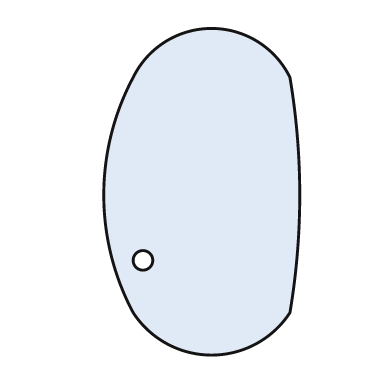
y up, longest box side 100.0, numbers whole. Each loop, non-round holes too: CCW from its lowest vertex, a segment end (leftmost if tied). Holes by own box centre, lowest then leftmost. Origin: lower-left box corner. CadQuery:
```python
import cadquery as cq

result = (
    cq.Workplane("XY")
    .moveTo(9.0, 13.0)
    .threePointArc((33.0, 0.0), (57.0, 13.0))
    .threePointArc((60.0, 49.0), (57.0, 85.0))
    .threePointArc((33.0, 100.0), (9.0, 85.0))
    .threePointArc((0.0, 49.0), (9.0, 13.0))
    .close()
    .moveTo(12.0, 29.0)
    .circle(3.0)
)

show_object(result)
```